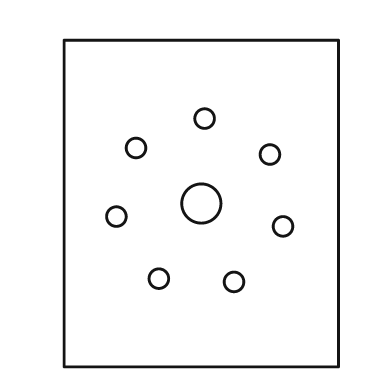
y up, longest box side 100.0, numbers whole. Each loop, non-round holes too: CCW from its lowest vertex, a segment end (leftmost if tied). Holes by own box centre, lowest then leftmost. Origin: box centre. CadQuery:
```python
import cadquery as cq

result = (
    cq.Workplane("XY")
    .moveTo(-42.0, -50.0)
    .lineTo(42.0, -50.0)
    .lineTo(42.0, 50.0)
    .lineTo(-42.0, 50.0)
    .close()
    .moveTo(10.0, -24.0)
    .circle(3.0)
    .moveTo(-13.0, -23.0)
    .circle(3.0)
    .moveTo(25.0, -7.0)
    .circle(3.0)
    .moveTo(-26.0, -4.0)
    .circle(3.0)
    .moveTo(0.0, 0.0)
    .circle(6.0)
    .moveTo(21.0, 15.0)
    .circle(3.0)
    .moveTo(-20.0, 17.0)
    .circle(3.0)
    .moveTo(1.0, 26.0)
    .circle(3.0)
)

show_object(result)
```